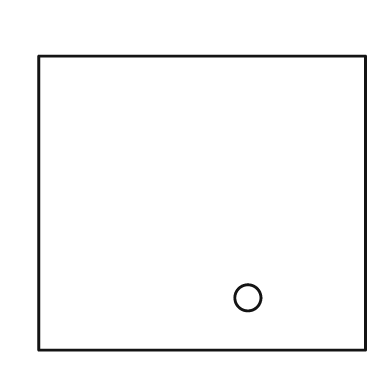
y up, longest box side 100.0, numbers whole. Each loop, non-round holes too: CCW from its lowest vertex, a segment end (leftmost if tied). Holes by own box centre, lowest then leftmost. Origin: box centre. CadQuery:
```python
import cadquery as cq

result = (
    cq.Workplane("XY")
    .moveTo(-50.0, -45.0)
    .lineTo(50.0, -45.0)
    .lineTo(50.0, 45.0)
    .lineTo(-50.0, 45.0)
    .close()
    .moveTo(14.0, -29.0)
    .circle(4.0)
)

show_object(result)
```